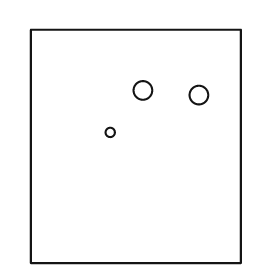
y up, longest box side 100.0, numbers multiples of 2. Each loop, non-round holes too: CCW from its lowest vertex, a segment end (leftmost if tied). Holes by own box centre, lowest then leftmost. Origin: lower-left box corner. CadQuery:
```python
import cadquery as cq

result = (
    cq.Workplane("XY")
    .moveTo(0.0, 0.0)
    .lineTo(90.0, 0.0)
    .lineTo(90.0, 100.0)
    .lineTo(0.0, 100.0)
    .close()
    .moveTo(34.0, 56.0)
    .circle(2.0)
    .moveTo(72.0, 72.0)
    .circle(4.0)
    .moveTo(48.0, 74.0)
    .circle(4.0)
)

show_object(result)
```